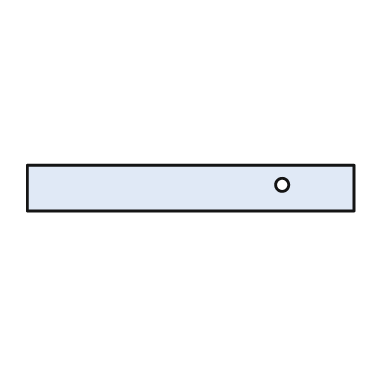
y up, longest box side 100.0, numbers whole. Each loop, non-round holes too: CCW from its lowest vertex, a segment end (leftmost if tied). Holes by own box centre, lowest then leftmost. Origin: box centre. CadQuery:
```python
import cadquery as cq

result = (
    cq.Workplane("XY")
    .moveTo(-50.0, -7.0)
    .lineTo(50.0, -7.0)
    .lineTo(50.0, 7.0)
    .lineTo(-50.0, 7.0)
    .close()
    .moveTo(28.0, 1.0)
    .circle(2.0)
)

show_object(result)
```